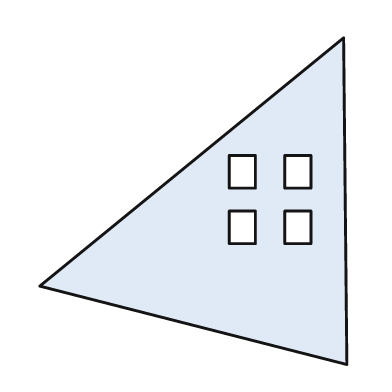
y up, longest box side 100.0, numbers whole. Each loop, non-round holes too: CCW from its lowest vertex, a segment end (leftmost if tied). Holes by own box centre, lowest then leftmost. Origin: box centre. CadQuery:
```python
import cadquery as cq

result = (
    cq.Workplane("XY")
    .moveTo(47.0, -50.0)
    .lineTo(46.0, 50.0)
    .lineTo(-47.0, -26.0)
    .close()
    .moveTo(11.0, -13.0)
    .lineTo(19.0, -13.0)
    .lineTo(19.0, -3.0)
    .lineTo(11.0, -3.0)
    .close()
    .moveTo(28.0, -13.0)
    .lineTo(36.0, -13.0)
    .lineTo(36.0, -3.0)
    .lineTo(28.0, -3.0)
    .close()
    .moveTo(11.0, 4.0)
    .lineTo(19.0, 4.0)
    .lineTo(19.0, 14.0)
    .lineTo(11.0, 14.0)
    .close()
    .moveTo(28.0, 4.0)
    .lineTo(36.0, 4.0)
    .lineTo(36.0, 14.0)
    .lineTo(28.0, 14.0)
    .close()
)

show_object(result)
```